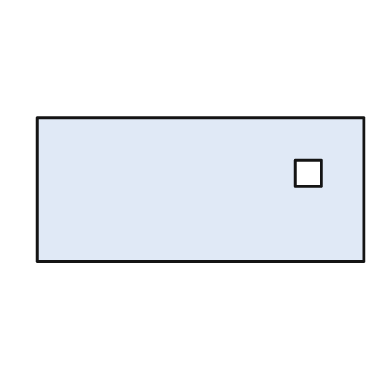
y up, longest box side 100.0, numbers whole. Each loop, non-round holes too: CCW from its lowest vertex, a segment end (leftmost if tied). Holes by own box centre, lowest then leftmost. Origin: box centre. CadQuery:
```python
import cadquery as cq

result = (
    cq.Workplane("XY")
    .moveTo(-50.0, -22.0)
    .lineTo(50.0, -22.0)
    .lineTo(50.0, 22.0)
    .lineTo(-50.0, 22.0)
    .close()
    .moveTo(29.0, 1.0)
    .lineTo(37.0, 1.0)
    .lineTo(37.0, 9.0)
    .lineTo(29.0, 9.0)
    .close()
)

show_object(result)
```